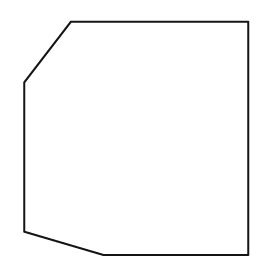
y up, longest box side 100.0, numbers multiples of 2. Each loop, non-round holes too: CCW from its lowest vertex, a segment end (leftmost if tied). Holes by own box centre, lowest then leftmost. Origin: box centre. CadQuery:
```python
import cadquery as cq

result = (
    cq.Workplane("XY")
    .moveTo(-14.0, -50.0)
    .lineTo(48.0, -50.0)
    .lineTo(48.0, 50.0)
    .lineTo(-28.0, 50.0)
    .lineTo(-48.0, 24.0)
    .lineTo(-48.0, -40.0)
    .close()
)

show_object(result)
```